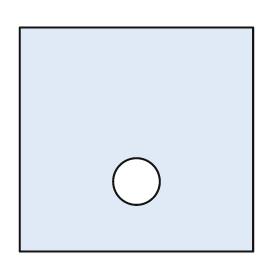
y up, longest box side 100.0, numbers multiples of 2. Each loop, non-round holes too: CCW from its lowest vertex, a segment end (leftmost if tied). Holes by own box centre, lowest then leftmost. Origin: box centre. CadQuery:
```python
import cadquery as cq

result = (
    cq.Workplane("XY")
    .moveTo(-50.0, -48.0)
    .lineTo(50.0, -48.0)
    .lineTo(50.0, 48.0)
    .lineTo(-50.0, 48.0)
    .close()
    .moveTo(0.0, -18.0)
    .circle(10.0)
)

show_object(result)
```